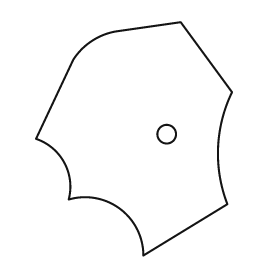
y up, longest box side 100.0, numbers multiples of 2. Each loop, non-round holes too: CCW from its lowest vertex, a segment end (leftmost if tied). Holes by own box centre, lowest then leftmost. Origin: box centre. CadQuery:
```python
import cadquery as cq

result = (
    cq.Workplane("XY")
    .moveTo(4.0, -50.0)
    .lineTo(40.0, -28.0)
    .threePointArc((36.0, -4.0), (42.0, 20.0))
    .lineTo(20.0, 50.0)
    .lineTo(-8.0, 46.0)
    .threePointArc((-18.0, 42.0), (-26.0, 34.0))
    .lineTo(-42.0, 0.0)
    .threePointArc((-30.0, -10.0), (-28.0, -26.0))
    .threePointArc((-6.0, -30.0), (4.0, -50.0))
    .close()
    .moveTo(14.0, 2.0)
    .circle(4.0)
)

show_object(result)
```